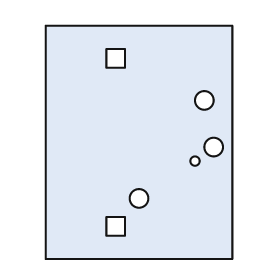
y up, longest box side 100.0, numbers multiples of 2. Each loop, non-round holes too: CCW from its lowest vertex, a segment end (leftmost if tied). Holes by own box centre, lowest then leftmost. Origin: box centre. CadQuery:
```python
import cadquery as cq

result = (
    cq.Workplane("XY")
    .moveTo(-40.0, -50.0)
    .lineTo(40.0, -50.0)
    .lineTo(40.0, 50.0)
    .lineTo(-40.0, 50.0)
    .close()
    .moveTo(-14.0, -40.0)
    .lineTo(-6.0, -40.0)
    .lineTo(-6.0, -32.0)
    .lineTo(-14.0, -32.0)
    .close()
    .moveTo(0.0, -24.0)
    .circle(4.0)
    .moveTo(24.0, -8.0)
    .circle(2.0)
    .moveTo(32.0, -2.0)
    .circle(4.0)
    .moveTo(28.0, 18.0)
    .circle(4.0)
    .moveTo(-14.0, 32.0)
    .lineTo(-6.0, 32.0)
    .lineTo(-6.0, 40.0)
    .lineTo(-14.0, 40.0)
    .close()
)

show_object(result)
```